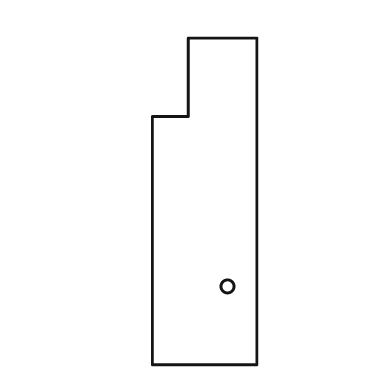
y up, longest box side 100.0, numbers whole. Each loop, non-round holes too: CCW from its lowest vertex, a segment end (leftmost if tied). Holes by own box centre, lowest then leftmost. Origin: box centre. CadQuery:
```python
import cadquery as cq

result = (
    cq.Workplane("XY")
    .moveTo(-16.0, -50.0)
    .lineTo(16.0, -50.0)
    .lineTo(16.0, 50.0)
    .lineTo(-5.0, 50.0)
    .lineTo(-5.0, 26.0)
    .lineTo(-16.0, 26.0)
    .close()
    .moveTo(7.0, -26.0)
    .circle(2.0)
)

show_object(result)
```